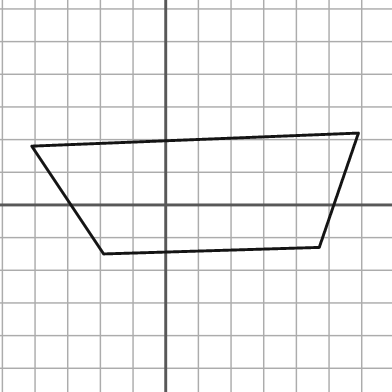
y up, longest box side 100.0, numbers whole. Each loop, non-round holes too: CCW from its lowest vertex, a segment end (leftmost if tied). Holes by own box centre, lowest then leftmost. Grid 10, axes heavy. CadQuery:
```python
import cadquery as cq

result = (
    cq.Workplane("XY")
    .moveTo(-19.0, -15.0)
    .lineTo(47.0, -13.0)
    .lineTo(59.0, 22.0)
    .lineTo(-41.0, 18.0)
    .close()
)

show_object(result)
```